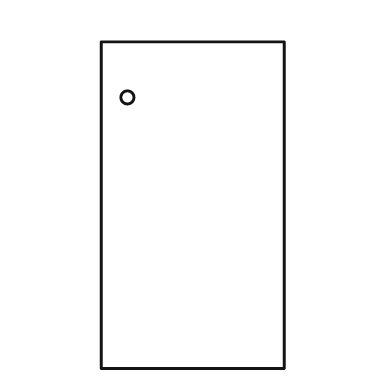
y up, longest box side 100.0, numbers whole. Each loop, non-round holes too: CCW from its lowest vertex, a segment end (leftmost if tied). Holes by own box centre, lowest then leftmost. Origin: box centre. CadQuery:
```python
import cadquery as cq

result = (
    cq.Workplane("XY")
    .moveTo(-28.0, -50.0)
    .lineTo(28.0, -50.0)
    .lineTo(28.0, 50.0)
    .lineTo(-28.0, 50.0)
    .close()
    .moveTo(-20.0, 33.0)
    .circle(2.0)
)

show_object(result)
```